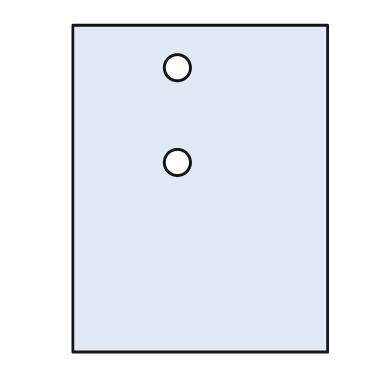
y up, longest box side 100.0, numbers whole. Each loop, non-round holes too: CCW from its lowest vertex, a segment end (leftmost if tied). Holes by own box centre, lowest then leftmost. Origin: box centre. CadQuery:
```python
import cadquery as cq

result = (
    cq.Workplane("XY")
    .moveTo(-39.0, -50.0)
    .lineTo(39.0, -50.0)
    .lineTo(39.0, 50.0)
    .lineTo(-39.0, 50.0)
    .close()
    .moveTo(-7.0, 8.0)
    .circle(4.0)
    .moveTo(-7.0, 37.0)
    .circle(4.0)
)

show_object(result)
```